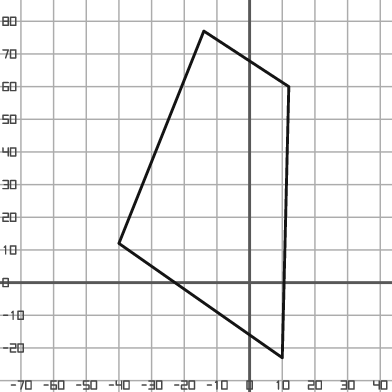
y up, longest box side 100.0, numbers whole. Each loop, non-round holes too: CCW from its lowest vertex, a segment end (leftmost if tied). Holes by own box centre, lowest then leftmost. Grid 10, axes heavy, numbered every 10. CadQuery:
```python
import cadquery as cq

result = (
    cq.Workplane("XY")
    .moveTo(10.0, -23.0)
    .lineTo(12.0, 60.0)
    .lineTo(-14.0, 77.0)
    .lineTo(-40.0, 12.0)
    .close()
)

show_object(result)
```